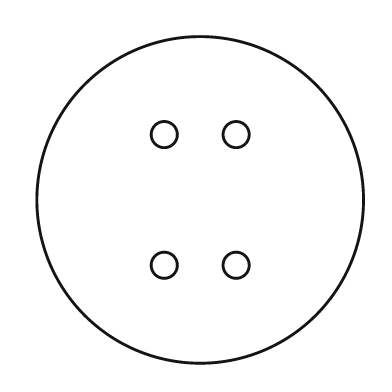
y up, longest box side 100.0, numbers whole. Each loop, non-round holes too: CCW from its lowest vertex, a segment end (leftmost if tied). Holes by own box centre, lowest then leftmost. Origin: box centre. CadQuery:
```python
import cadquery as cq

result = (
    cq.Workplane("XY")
    .moveTo(0.0, 0.0)
    .circle(50.0)
    .moveTo(-11.0, -20.0)
    .circle(4.0)
    .moveTo(11.0, -20.0)
    .circle(4.0)
    .moveTo(-11.0, 20.0)
    .circle(4.0)
    .moveTo(11.0, 20.0)
    .circle(4.0)
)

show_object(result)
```